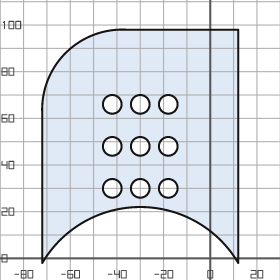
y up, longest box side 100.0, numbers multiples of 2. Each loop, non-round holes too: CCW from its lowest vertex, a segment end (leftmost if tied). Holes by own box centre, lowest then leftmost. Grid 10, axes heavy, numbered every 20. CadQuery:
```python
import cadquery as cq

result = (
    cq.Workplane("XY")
    .moveTo(-72.0, -2.0)
    .threePointArc((-30.0, 22.0), (12.0, -2.0))
    .lineTo(12.0, 98.0)
    .lineTo(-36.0, 98.0)
    .threePointArc((-62.0, 88.0), (-72.0, 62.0))
    .close()
    .moveTo(-42.0, 30.0)
    .circle(4.0)
    .moveTo(-30.0, 30.0)
    .circle(4.0)
    .moveTo(-18.0, 30.0)
    .circle(4.0)
    .moveTo(-42.0, 48.0)
    .circle(4.0)
    .moveTo(-30.0, 48.0)
    .circle(4.0)
    .moveTo(-18.0, 48.0)
    .circle(4.0)
    .moveTo(-42.0, 66.0)
    .circle(4.0)
    .moveTo(-30.0, 66.0)
    .circle(4.0)
    .moveTo(-18.0, 66.0)
    .circle(4.0)
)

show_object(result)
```